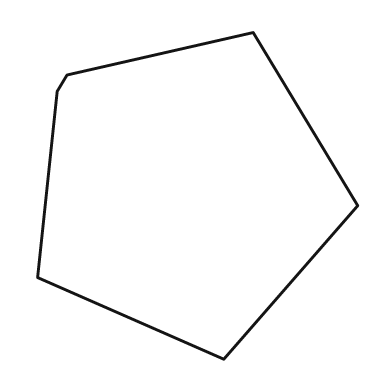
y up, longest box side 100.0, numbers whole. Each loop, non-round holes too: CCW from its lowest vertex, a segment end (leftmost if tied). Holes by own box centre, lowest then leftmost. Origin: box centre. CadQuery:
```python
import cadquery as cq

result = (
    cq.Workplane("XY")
    .moveTo(8.0, -50.0)
    .lineTo(49.0, -3.0)
    .lineTo(17.0, 50.0)
    .lineTo(-40.0, 37.0)
    .lineTo(-43.0, 32.0)
    .lineTo(-49.0, -25.0)
    .close()
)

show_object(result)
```